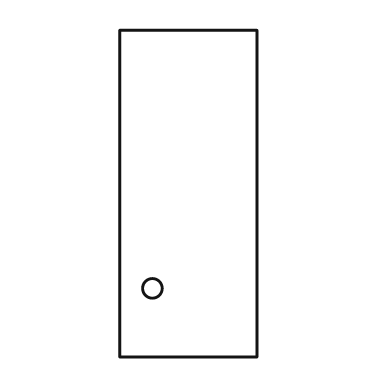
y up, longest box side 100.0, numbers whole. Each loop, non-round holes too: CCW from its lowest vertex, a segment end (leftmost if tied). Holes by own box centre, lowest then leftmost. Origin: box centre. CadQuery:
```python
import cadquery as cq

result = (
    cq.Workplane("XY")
    .moveTo(-21.0, -50.0)
    .lineTo(21.0, -50.0)
    .lineTo(21.0, 50.0)
    .lineTo(-21.0, 50.0)
    .close()
    .moveTo(-11.0, -29.0)
    .circle(3.0)
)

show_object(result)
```